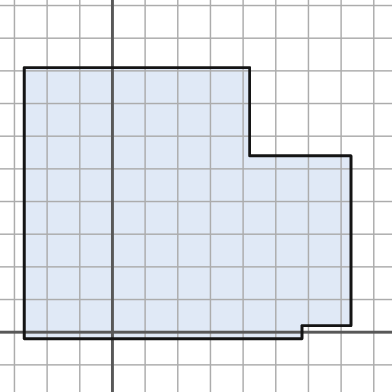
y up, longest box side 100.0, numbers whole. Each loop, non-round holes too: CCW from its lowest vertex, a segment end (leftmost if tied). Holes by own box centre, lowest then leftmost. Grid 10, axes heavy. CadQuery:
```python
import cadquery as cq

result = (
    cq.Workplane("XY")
    .moveTo(-27.0, -2.0)
    .lineTo(58.0, -2.0)
    .lineTo(58.0, 2.0)
    .lineTo(73.0, 2.0)
    .lineTo(73.0, 54.0)
    .lineTo(42.0, 54.0)
    .lineTo(42.0, 81.0)
    .lineTo(-27.0, 81.0)
    .close()
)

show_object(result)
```